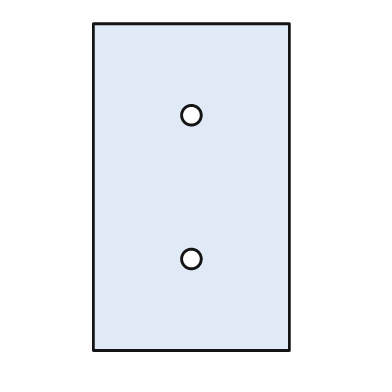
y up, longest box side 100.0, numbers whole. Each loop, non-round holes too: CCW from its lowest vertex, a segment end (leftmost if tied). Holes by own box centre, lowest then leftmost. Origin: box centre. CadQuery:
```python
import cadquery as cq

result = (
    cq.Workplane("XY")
    .moveTo(-30.0, -50.0)
    .lineTo(30.0, -50.0)
    .lineTo(30.0, 50.0)
    .lineTo(-30.0, 50.0)
    .close()
    .moveTo(0.0, -22.0)
    .circle(3.0)
    .moveTo(0.0, 22.0)
    .circle(3.0)
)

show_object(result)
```